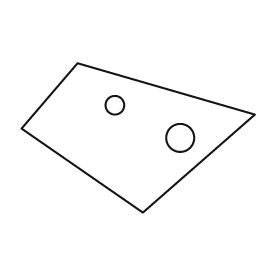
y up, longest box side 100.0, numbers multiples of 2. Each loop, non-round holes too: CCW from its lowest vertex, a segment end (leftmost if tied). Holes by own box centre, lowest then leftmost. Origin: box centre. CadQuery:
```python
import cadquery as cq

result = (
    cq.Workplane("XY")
    .moveTo(2.0, -32.0)
    .lineTo(50.0, 10.0)
    .lineTo(-26.0, 32.0)
    .lineTo(-50.0, 4.0)
    .close()
    .moveTo(18.0, 0.0)
    .circle(6.0)
    .moveTo(-10.0, 14.0)
    .circle(4.0)
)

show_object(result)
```